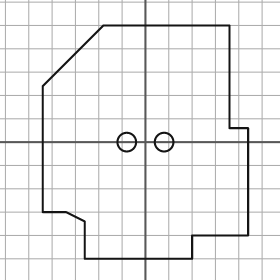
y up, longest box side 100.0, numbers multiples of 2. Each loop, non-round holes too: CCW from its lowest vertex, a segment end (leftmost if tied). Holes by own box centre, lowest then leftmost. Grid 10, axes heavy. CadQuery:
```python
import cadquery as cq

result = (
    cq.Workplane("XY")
    .moveTo(-26.0, -50.0)
    .lineTo(20.0, -50.0)
    .lineTo(20.0, -40.0)
    .lineTo(44.0, -40.0)
    .lineTo(44.0, 6.0)
    .lineTo(36.0, 6.0)
    .lineTo(36.0, 50.0)
    .lineTo(-18.0, 50.0)
    .lineTo(-44.0, 24.0)
    .lineTo(-44.0, -30.0)
    .lineTo(-34.0, -30.0)
    .lineTo(-26.0, -34.0)
    .close()
    .moveTo(-8.0, 0.0)
    .circle(4.0)
    .moveTo(8.0, 0.0)
    .circle(4.0)
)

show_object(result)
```